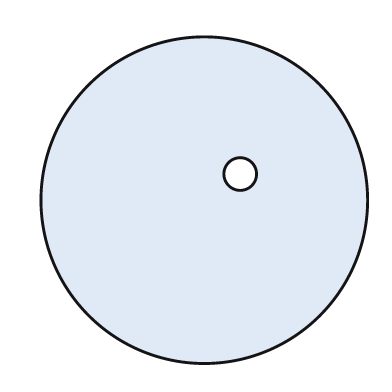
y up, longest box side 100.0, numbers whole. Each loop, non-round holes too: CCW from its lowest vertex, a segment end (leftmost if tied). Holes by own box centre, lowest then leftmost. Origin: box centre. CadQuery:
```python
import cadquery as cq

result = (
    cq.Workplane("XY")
    .moveTo(0.0, 0.0)
    .circle(50.0)
    .moveTo(11.0, 8.0)
    .circle(5.0)
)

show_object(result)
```